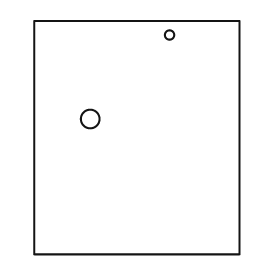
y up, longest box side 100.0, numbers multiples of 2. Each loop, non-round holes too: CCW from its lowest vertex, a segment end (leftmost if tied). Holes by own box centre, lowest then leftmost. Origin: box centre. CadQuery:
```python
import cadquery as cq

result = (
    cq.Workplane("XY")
    .moveTo(-44.0, -50.0)
    .lineTo(44.0, -50.0)
    .lineTo(44.0, 50.0)
    .lineTo(-44.0, 50.0)
    .close()
    .moveTo(-20.0, 8.0)
    .circle(4.0)
    .moveTo(14.0, 44.0)
    .circle(2.0)
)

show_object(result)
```